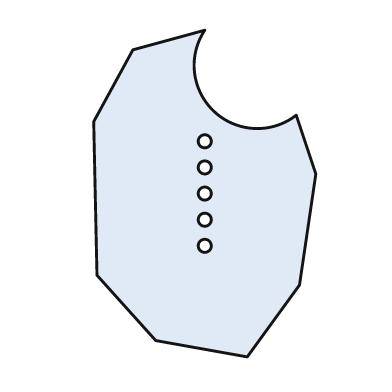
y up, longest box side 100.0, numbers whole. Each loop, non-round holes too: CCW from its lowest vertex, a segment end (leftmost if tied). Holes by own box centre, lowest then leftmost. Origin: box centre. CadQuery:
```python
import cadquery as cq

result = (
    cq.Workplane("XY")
    .moveTo(13.0, -50.0)
    .lineTo(29.0, -28.0)
    .lineTo(34.0, 6.0)
    .lineTo(28.0, 24.0)
    .threePointArc((3.0, 25.0), (0.0, 50.0))
    .lineTo(-22.0, 44.0)
    .lineTo(-34.0, 22.0)
    .lineTo(-33.0, -25.0)
    .lineTo(-15.0, -45.0)
    .close()
    .moveTo(0.0, -16.0)
    .circle(2.0)
    .moveTo(0.0, -8.0)
    .circle(2.0)
    .moveTo(0.0, 0.0)
    .circle(2.0)
    .moveTo(0.0, 8.0)
    .circle(2.0)
    .moveTo(0.0, 16.0)
    .circle(2.0)
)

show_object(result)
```